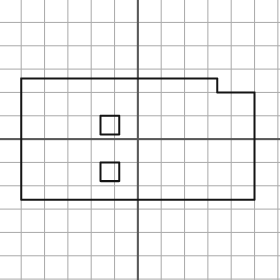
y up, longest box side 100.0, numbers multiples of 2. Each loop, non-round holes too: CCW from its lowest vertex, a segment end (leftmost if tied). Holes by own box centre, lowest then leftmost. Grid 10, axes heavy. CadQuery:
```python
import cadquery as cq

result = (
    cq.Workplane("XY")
    .moveTo(-50.0, -26.0)
    .lineTo(50.0, -26.0)
    .lineTo(50.0, 20.0)
    .lineTo(34.0, 20.0)
    .lineTo(34.0, 26.0)
    .lineTo(-50.0, 26.0)
    .close()
    .moveTo(-16.0, -18.0)
    .lineTo(-8.0, -18.0)
    .lineTo(-8.0, -10.0)
    .lineTo(-16.0, -10.0)
    .close()
    .moveTo(-16.0, 2.0)
    .lineTo(-8.0, 2.0)
    .lineTo(-8.0, 10.0)
    .lineTo(-16.0, 10.0)
    .close()
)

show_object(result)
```